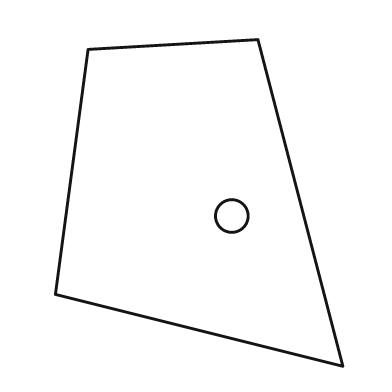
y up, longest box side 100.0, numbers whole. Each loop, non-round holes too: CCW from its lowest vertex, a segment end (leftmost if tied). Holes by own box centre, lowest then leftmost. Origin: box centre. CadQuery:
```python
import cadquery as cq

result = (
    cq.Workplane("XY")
    .moveTo(44.0, -50.0)
    .lineTo(18.0, 50.0)
    .lineTo(-34.0, 47.0)
    .lineTo(-44.0, -28.0)
    .close()
    .moveTo(10.0, -4.0)
    .circle(5.0)
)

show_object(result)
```